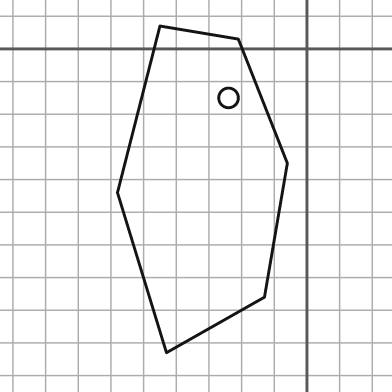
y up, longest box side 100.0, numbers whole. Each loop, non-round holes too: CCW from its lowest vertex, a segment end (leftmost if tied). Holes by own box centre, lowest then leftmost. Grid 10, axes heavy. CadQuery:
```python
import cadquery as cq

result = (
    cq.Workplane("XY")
    .moveTo(-43.0, -93.0)
    .lineTo(-13.0, -76.0)
    .lineTo(-6.0, -35.0)
    .lineTo(-21.0, 3.0)
    .lineTo(-45.0, 7.0)
    .lineTo(-58.0, -44.0)
    .close()
    .moveTo(-24.0, -15.0)
    .circle(3.0)
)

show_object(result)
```